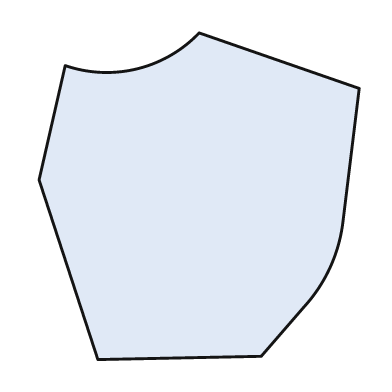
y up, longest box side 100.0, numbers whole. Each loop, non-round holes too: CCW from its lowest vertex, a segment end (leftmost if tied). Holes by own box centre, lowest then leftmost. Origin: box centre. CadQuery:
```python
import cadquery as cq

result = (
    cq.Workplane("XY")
    .moveTo(-31.0, -50.0)
    .lineTo(19.0, -49.0)
    .lineTo(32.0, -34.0)
    .threePointArc((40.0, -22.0), (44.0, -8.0))
    .lineTo(49.0, 33.0)
    .lineTo(0.0, 50.0)
    .threePointArc((-19.0, 39.0), (-41.0, 40.0))
    .lineTo(-49.0, 5.0)
    .close()
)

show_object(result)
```